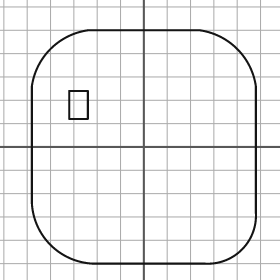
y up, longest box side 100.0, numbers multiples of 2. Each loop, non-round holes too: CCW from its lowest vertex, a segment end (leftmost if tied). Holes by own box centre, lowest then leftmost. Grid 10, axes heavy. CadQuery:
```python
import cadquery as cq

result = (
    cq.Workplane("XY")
    .moveTo(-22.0, -50.0)
    .lineTo(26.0, -50.0)
    .threePointArc((42.0, -44.0), (48.0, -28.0))
    .lineTo(48.0, 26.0)
    .threePointArc((40.0, 42.0), (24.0, 50.0))
    .lineTo(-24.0, 50.0)
    .threePointArc((-40.0, 42.0), (-48.0, 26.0))
    .lineTo(-48.0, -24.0)
    .threePointArc((-40.0, -42.0), (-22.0, -50.0))
    .close()
    .moveTo(-32.0, 12.0)
    .lineTo(-24.0, 12.0)
    .lineTo(-24.0, 24.0)
    .lineTo(-32.0, 24.0)
    .close()
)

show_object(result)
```